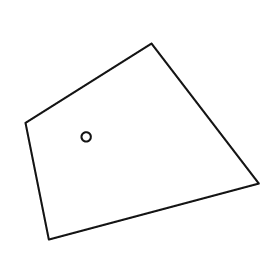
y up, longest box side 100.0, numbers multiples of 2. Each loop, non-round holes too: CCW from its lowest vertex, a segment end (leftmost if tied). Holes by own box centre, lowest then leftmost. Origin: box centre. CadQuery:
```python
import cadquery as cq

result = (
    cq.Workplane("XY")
    .moveTo(-40.0, -42.0)
    .lineTo(50.0, -18.0)
    .lineTo(4.0, 42.0)
    .lineTo(-50.0, 8.0)
    .close()
    .moveTo(-24.0, 2.0)
    .circle(2.0)
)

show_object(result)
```